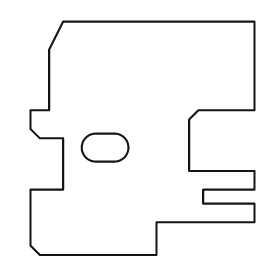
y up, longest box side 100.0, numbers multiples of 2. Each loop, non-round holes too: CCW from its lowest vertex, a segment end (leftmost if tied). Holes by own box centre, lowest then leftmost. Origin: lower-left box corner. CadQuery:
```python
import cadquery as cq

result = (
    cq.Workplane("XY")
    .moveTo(4.0, 0.0)
    .lineTo(54.0, 0.0)
    .lineTo(54.0, 14.0)
    .lineTo(96.0, 14.0)
    .lineTo(96.0, 22.0)
    .lineTo(74.0, 22.0)
    .lineTo(74.0, 28.0)
    .lineTo(96.0, 28.0)
    .lineTo(96.0, 36.0)
    .lineTo(68.0, 36.0)
    .lineTo(68.0, 58.0)
    .lineTo(72.0, 62.0)
    .lineTo(96.0, 62.0)
    .lineTo(96.0, 100.0)
    .lineTo(14.0, 100.0)
    .lineTo(8.0, 88.0)
    .lineTo(8.0, 62.0)
    .lineTo(0.0, 62.0)
    .lineTo(0.0, 54.0)
    .lineTo(4.0, 50.0)
    .lineTo(14.0, 50.0)
    .lineTo(14.0, 28.0)
    .lineTo(0.0, 28.0)
    .lineTo(0.0, 4.0)
    .close()
    .moveTo(28.0, 40.0)
    .lineTo(36.0, 40.0)
    .threePointArc((42.0, 46.0), (36.0, 52.0))
    .lineTo(28.0, 52.0)
    .threePointArc((22.0, 46.0), (28.0, 40.0))
    .close()
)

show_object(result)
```